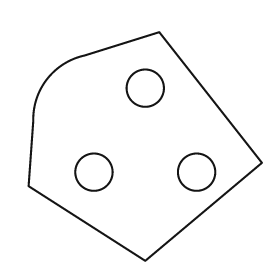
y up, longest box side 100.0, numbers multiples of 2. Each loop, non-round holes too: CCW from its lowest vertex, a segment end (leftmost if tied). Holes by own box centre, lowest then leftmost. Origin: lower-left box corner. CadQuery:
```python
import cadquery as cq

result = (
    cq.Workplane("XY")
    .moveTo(50.0, 0.0)
    .lineTo(100.0, 42.0)
    .lineTo(56.0, 98.0)
    .lineTo(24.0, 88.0)
    .threePointArc((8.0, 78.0), (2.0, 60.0))
    .lineTo(0.0, 32.0)
    .close()
    .moveTo(28.0, 38.0)
    .circle(8.0)
    .moveTo(72.0, 38.0)
    .circle(8.0)
    .moveTo(50.0, 74.0)
    .circle(8.0)
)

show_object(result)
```